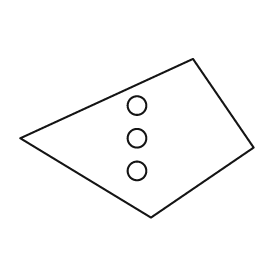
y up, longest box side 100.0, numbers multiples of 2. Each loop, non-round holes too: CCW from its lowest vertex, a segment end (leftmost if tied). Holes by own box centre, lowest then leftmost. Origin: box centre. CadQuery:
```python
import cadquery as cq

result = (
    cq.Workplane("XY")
    .moveTo(6.0, -34.0)
    .lineTo(50.0, -4.0)
    .lineTo(24.0, 34.0)
    .lineTo(-50.0, 0.0)
    .close()
    .moveTo(0.0, -14.0)
    .circle(4.0)
    .moveTo(0.0, 0.0)
    .circle(4.0)
    .moveTo(0.0, 14.0)
    .circle(4.0)
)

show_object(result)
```